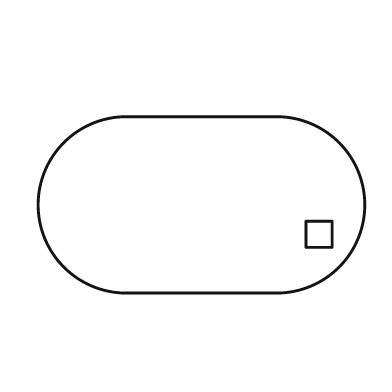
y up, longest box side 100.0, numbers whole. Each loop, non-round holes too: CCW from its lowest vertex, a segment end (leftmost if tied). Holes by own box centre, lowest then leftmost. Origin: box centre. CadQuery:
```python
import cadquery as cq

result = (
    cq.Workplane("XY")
    .moveTo(-23.0, -27.0)
    .lineTo(23.0, -27.0)
    .threePointArc((50.0, 0.0), (23.0, 27.0))
    .lineTo(-23.0, 27.0)
    .threePointArc((-50.0, 0.0), (-23.0, -27.0))
    .close()
    .moveTo(32.0, -13.0)
    .lineTo(40.0, -13.0)
    .lineTo(40.0, -5.0)
    .lineTo(32.0, -5.0)
    .close()
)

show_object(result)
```